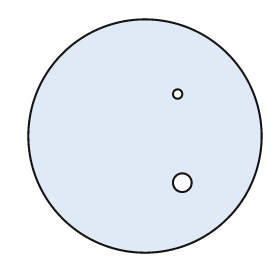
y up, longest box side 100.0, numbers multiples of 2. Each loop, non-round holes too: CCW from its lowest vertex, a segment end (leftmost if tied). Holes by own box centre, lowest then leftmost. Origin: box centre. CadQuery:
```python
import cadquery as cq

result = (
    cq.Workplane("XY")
    .moveTo(0.0, 0.0)
    .circle(50.0)
    .moveTo(16.0, -20.0)
    .circle(4.0)
    .moveTo(14.0, 18.0)
    .circle(2.0)
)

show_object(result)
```